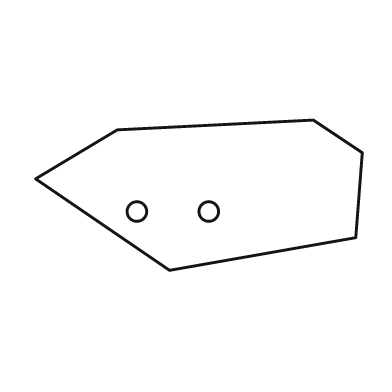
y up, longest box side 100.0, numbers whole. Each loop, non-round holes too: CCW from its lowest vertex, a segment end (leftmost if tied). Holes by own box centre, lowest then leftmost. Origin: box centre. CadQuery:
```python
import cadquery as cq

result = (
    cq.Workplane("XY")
    .moveTo(-9.0, -23.0)
    .lineTo(48.0, -13.0)
    .lineTo(50.0, 13.0)
    .lineTo(35.0, 23.0)
    .lineTo(-25.0, 20.0)
    .lineTo(-50.0, 5.0)
    .close()
    .moveTo(-19.0, -5.0)
    .circle(3.0)
    .moveTo(3.0, -5.0)
    .circle(3.0)
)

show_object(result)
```